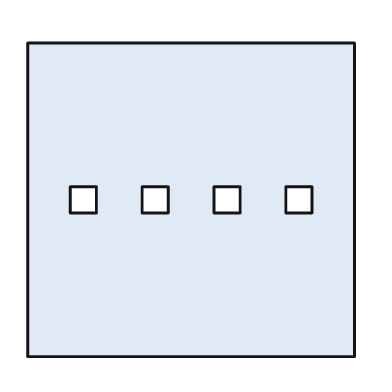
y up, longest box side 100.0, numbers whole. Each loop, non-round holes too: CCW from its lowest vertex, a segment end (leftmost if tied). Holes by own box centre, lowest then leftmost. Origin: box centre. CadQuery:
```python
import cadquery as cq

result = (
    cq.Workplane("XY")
    .moveTo(-50.0, -48.0)
    .lineTo(50.0, -48.0)
    .lineTo(50.0, 48.0)
    .lineTo(-50.0, 48.0)
    .close()
    .moveTo(-37.0, -4.0)
    .lineTo(-29.0, -4.0)
    .lineTo(-29.0, 4.0)
    .lineTo(-37.0, 4.0)
    .close()
    .moveTo(-15.0, -4.0)
    .lineTo(-7.0, -4.0)
    .lineTo(-7.0, 4.0)
    .lineTo(-15.0, 4.0)
    .close()
    .moveTo(7.0, -4.0)
    .lineTo(15.0, -4.0)
    .lineTo(15.0, 4.0)
    .lineTo(7.0, 4.0)
    .close()
    .moveTo(29.0, -4.0)
    .lineTo(37.0, -4.0)
    .lineTo(37.0, 4.0)
    .lineTo(29.0, 4.0)
    .close()
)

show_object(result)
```